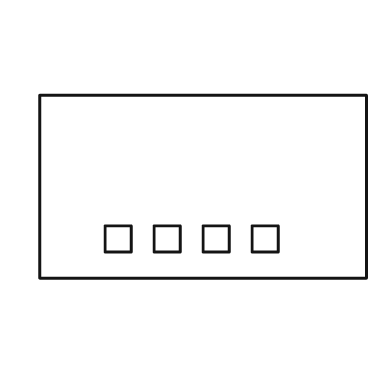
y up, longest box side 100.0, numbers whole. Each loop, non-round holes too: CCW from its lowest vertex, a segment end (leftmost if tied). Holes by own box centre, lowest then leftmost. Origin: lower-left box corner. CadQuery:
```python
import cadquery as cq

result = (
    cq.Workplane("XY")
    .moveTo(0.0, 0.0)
    .lineTo(100.0, 0.0)
    .lineTo(100.0, 56.0)
    .lineTo(0.0, 56.0)
    .close()
    .moveTo(20.0, 8.0)
    .lineTo(28.0, 8.0)
    .lineTo(28.0, 16.0)
    .lineTo(20.0, 16.0)
    .close()
    .moveTo(35.0, 8.0)
    .lineTo(43.0, 8.0)
    .lineTo(43.0, 16.0)
    .lineTo(35.0, 16.0)
    .close()
    .moveTo(50.0, 8.0)
    .lineTo(58.0, 8.0)
    .lineTo(58.0, 16.0)
    .lineTo(50.0, 16.0)
    .close()
    .moveTo(65.0, 8.0)
    .lineTo(73.0, 8.0)
    .lineTo(73.0, 16.0)
    .lineTo(65.0, 16.0)
    .close()
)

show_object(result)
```